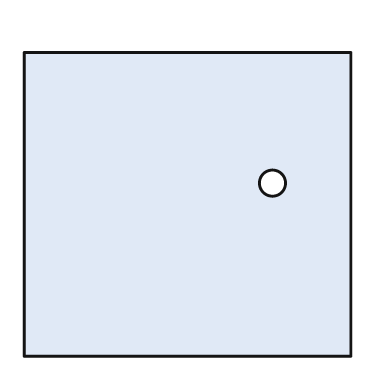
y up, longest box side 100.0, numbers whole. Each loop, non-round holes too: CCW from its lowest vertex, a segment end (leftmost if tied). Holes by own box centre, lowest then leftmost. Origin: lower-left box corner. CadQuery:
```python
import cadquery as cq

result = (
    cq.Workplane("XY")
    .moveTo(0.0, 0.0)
    .lineTo(100.0, 0.0)
    .lineTo(100.0, 93.0)
    .lineTo(0.0, 93.0)
    .close()
    .moveTo(76.0, 53.0)
    .circle(4.0)
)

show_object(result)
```